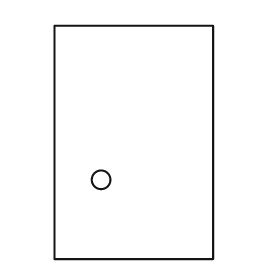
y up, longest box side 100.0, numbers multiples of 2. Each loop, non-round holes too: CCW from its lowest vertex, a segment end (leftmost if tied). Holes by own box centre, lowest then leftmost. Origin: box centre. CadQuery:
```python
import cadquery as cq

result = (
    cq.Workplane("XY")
    .moveTo(-34.0, -50.0)
    .lineTo(34.0, -50.0)
    .lineTo(34.0, 50.0)
    .lineTo(-34.0, 50.0)
    .close()
    .moveTo(-14.0, -16.0)
    .circle(4.0)
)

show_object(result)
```